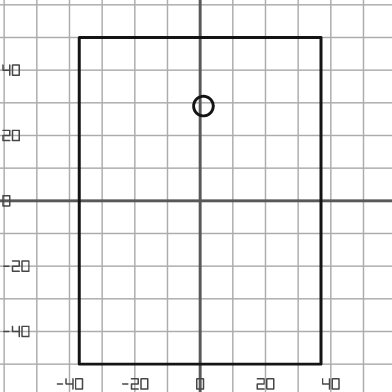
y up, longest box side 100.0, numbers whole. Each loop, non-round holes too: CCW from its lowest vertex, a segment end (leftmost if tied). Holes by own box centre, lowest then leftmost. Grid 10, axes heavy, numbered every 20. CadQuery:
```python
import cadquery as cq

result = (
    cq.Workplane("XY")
    .moveTo(-37.0, -50.0)
    .lineTo(37.0, -50.0)
    .lineTo(37.0, 50.0)
    .lineTo(-37.0, 50.0)
    .close()
    .moveTo(1.0, 29.0)
    .circle(3.0)
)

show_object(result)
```